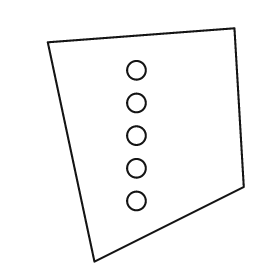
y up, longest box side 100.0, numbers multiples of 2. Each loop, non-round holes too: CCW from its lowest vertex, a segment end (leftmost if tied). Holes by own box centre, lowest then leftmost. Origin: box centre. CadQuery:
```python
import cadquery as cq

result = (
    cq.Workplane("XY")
    .moveTo(-22.0, -50.0)
    .lineTo(42.0, -18.0)
    .lineTo(38.0, 50.0)
    .lineTo(-42.0, 44.0)
    .close()
    .moveTo(-4.0, -24.0)
    .circle(4.0)
    .moveTo(-4.0, -10.0)
    .circle(4.0)
    .moveTo(-4.0, 4.0)
    .circle(4.0)
    .moveTo(-4.0, 18.0)
    .circle(4.0)
    .moveTo(-4.0, 32.0)
    .circle(4.0)
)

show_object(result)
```